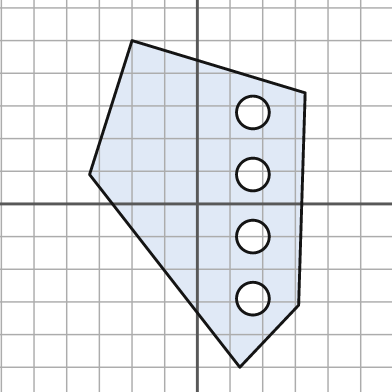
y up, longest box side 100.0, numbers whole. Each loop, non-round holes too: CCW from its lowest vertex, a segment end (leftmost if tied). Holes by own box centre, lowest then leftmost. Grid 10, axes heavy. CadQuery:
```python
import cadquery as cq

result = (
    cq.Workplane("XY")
    .moveTo(13.0, -50.0)
    .lineTo(31.0, -31.0)
    .lineTo(33.0, 34.0)
    .lineTo(-20.0, 50.0)
    .lineTo(-33.0, 9.0)
    .close()
    .moveTo(17.0, -29.0)
    .circle(5.0)
    .moveTo(17.0, -10.0)
    .circle(5.0)
    .moveTo(17.0, 9.0)
    .circle(5.0)
    .moveTo(17.0, 28.0)
    .circle(5.0)
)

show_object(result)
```